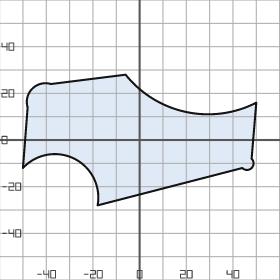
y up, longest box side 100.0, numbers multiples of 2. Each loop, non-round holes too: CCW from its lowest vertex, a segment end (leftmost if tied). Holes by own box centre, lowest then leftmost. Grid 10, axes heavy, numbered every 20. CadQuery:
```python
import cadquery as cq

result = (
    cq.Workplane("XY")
    .moveTo(-18.0, -28.0)
    .lineTo(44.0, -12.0)
    .threePointArc((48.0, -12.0), (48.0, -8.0))
    .lineTo(50.0, 16.0)
    .threePointArc((20.0, 12.0), (-6.0, 28.0))
    .lineTo(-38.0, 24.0)
    .threePointArc((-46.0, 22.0), (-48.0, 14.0))
    .lineTo(-50.0, -12.0)
    .threePointArc((-28.0, -8.0), (-18.0, -28.0))
    .close()
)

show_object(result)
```